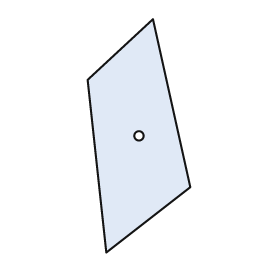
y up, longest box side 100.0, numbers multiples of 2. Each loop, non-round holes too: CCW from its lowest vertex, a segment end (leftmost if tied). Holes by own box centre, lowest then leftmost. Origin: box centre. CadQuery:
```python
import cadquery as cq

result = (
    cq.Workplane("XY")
    .moveTo(-14.0, -50.0)
    .lineTo(22.0, -22.0)
    .lineTo(6.0, 50.0)
    .lineTo(-22.0, 24.0)
    .close()
    .moveTo(0.0, 0.0)
    .circle(2.0)
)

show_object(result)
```